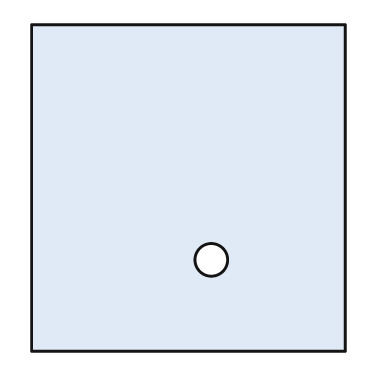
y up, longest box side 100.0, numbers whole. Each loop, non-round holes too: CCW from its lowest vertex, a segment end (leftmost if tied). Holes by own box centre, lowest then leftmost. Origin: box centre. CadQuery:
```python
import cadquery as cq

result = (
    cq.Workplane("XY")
    .moveTo(-48.0, -50.0)
    .lineTo(48.0, -50.0)
    .lineTo(48.0, 50.0)
    .lineTo(-48.0, 50.0)
    .close()
    .moveTo(7.0, -22.0)
    .circle(5.0)
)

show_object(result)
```